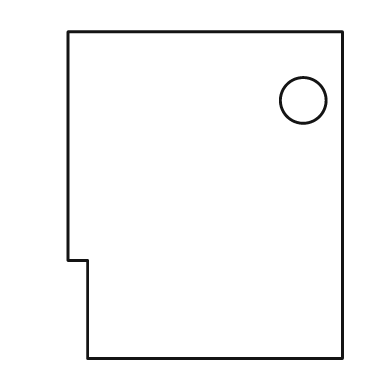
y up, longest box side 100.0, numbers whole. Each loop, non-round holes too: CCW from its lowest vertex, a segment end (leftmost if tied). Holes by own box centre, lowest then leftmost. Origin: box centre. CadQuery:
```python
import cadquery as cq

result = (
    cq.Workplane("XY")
    .moveTo(-36.0, -50.0)
    .lineTo(42.0, -50.0)
    .lineTo(42.0, 50.0)
    .lineTo(-42.0, 50.0)
    .lineTo(-42.0, -20.0)
    .lineTo(-36.0, -20.0)
    .close()
    .moveTo(30.0, 29.0)
    .circle(7.0)
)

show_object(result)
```